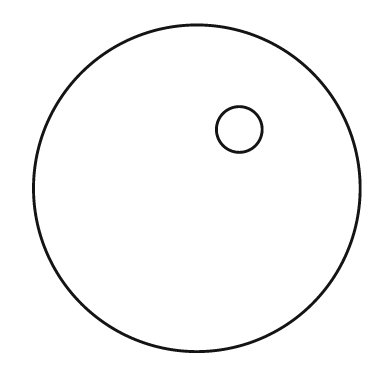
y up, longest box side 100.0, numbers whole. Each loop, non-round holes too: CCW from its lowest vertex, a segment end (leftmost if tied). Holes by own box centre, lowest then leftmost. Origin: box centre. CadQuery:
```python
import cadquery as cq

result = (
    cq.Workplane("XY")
    .moveTo(0.0, 0.0)
    .circle(50.0)
    .moveTo(13.0, 18.0)
    .circle(7.0)
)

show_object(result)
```